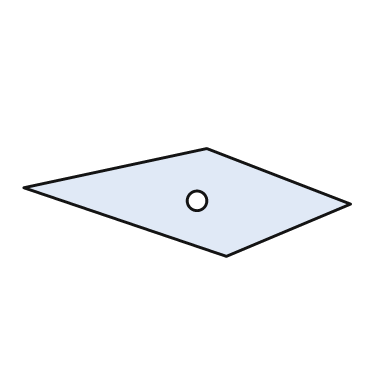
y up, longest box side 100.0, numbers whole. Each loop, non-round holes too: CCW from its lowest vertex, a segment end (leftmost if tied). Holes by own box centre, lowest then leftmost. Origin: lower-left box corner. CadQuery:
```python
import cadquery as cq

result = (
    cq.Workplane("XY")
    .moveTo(62.0, 0.0)
    .lineTo(100.0, 16.0)
    .lineTo(56.0, 33.0)
    .lineTo(0.0, 21.0)
    .close()
    .moveTo(53.0, 17.0)
    .circle(3.0)
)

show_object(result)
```